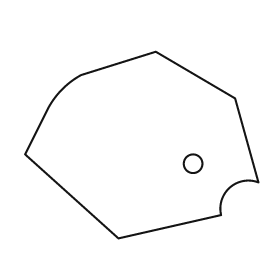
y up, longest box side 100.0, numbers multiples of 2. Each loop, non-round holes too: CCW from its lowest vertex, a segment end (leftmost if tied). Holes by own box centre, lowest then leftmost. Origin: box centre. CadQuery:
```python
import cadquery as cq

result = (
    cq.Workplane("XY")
    .moveTo(-10.0, -40.0)
    .lineTo(34.0, -30.0)
    .threePointArc((38.0, -18.0), (50.0, -16.0))
    .lineTo(40.0, 20.0)
    .lineTo(6.0, 40.0)
    .lineTo(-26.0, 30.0)
    .threePointArc((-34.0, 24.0), (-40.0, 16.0))
    .lineTo(-50.0, -4.0)
    .close()
    .moveTo(22.0, -8.0)
    .circle(4.0)
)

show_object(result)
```